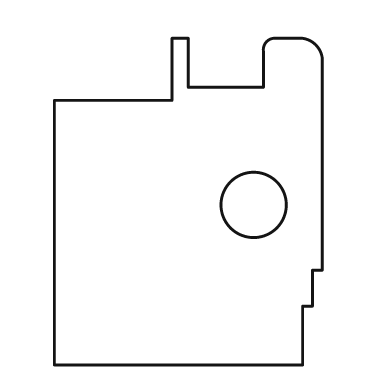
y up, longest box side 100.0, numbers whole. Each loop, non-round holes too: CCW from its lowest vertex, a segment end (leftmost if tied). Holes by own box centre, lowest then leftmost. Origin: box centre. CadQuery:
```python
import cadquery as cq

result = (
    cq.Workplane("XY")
    .moveTo(-41.0, -50.0)
    .lineTo(35.0, -50.0)
    .lineTo(35.0, -32.0)
    .lineTo(38.0, -32.0)
    .lineTo(38.0, -21.0)
    .lineTo(41.0, -21.0)
    .lineTo(41.0, 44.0)
    .threePointArc((39.0, 48.0), (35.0, 50.0))
    .lineTo(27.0, 50.0)
    .threePointArc((24.0, 49.0), (23.0, 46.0))
    .lineTo(23.0, 35.0)
    .lineTo(0.0, 35.0)
    .lineTo(0.0, 50.0)
    .lineTo(-5.0, 50.0)
    .lineTo(-5.0, 31.0)
    .lineTo(-41.0, 31.0)
    .close()
    .moveTo(20.0, -1.0)
    .circle(10.0)
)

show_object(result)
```